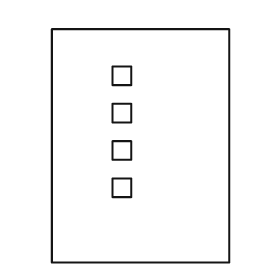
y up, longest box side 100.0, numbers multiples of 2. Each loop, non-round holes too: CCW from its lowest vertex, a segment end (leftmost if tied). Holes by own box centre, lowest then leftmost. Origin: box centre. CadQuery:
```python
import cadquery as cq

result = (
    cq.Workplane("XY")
    .moveTo(-38.0, -50.0)
    .lineTo(38.0, -50.0)
    .lineTo(38.0, 50.0)
    .lineTo(-38.0, 50.0)
    .close()
    .moveTo(-12.0, -22.0)
    .lineTo(-4.0, -22.0)
    .lineTo(-4.0, -14.0)
    .lineTo(-12.0, -14.0)
    .close()
    .moveTo(-12.0, -6.0)
    .lineTo(-4.0, -6.0)
    .lineTo(-4.0, 2.0)
    .lineTo(-12.0, 2.0)
    .close()
    .moveTo(-12.0, 10.0)
    .lineTo(-4.0, 10.0)
    .lineTo(-4.0, 18.0)
    .lineTo(-12.0, 18.0)
    .close()
    .moveTo(-12.0, 26.0)
    .lineTo(-4.0, 26.0)
    .lineTo(-4.0, 34.0)
    .lineTo(-12.0, 34.0)
    .close()
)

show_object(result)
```